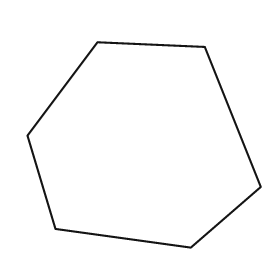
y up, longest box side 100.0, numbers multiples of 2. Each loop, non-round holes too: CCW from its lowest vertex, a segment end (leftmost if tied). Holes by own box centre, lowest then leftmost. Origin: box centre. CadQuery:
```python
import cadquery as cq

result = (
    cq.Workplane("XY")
    .moveTo(20.0, -44.0)
    .lineTo(50.0, -18.0)
    .lineTo(26.0, 42.0)
    .lineTo(-20.0, 44.0)
    .lineTo(-50.0, 4.0)
    .lineTo(-38.0, -36.0)
    .close()
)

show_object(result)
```